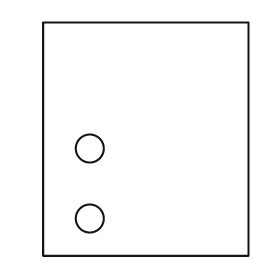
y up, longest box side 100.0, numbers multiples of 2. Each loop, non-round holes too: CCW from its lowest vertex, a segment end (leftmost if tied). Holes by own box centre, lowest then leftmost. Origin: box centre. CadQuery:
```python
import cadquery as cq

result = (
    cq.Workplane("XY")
    .moveTo(-44.0, -50.0)
    .lineTo(44.0, -50.0)
    .lineTo(44.0, 50.0)
    .lineTo(-44.0, 50.0)
    .close()
    .moveTo(-24.0, -34.0)
    .circle(6.0)
    .moveTo(-24.0, -4.0)
    .circle(6.0)
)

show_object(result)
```